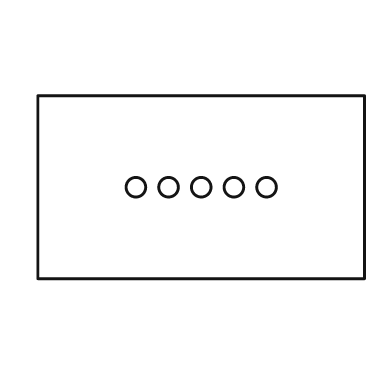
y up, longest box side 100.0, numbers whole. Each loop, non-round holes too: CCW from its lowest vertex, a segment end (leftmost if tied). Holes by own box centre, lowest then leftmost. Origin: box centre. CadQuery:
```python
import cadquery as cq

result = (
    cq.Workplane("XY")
    .moveTo(-50.0, -28.0)
    .lineTo(50.0, -28.0)
    .lineTo(50.0, 28.0)
    .lineTo(-50.0, 28.0)
    .close()
    .moveTo(-20.0, 0.0)
    .circle(3.0)
    .moveTo(-10.0, 0.0)
    .circle(3.0)
    .moveTo(0.0, 0.0)
    .circle(3.0)
    .moveTo(10.0, 0.0)
    .circle(3.0)
    .moveTo(20.0, 0.0)
    .circle(3.0)
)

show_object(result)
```